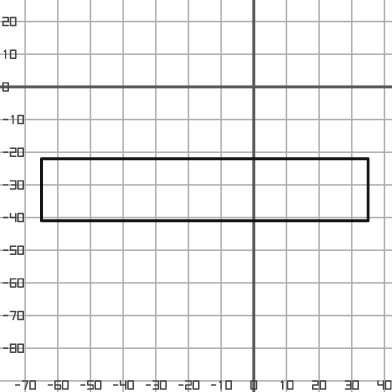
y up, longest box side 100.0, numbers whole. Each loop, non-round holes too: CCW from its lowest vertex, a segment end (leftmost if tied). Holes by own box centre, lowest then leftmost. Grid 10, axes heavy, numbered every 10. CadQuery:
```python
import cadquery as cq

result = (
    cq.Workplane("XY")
    .moveTo(-65.0, -41.0)
    .lineTo(35.0, -41.0)
    .lineTo(35.0, -22.0)
    .lineTo(-65.0, -22.0)
    .close()
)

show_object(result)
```